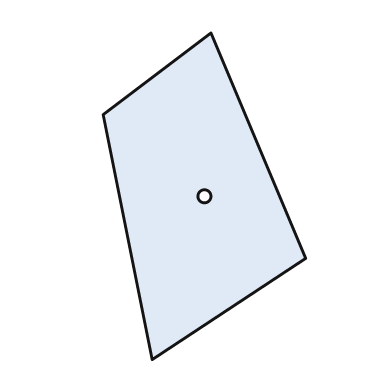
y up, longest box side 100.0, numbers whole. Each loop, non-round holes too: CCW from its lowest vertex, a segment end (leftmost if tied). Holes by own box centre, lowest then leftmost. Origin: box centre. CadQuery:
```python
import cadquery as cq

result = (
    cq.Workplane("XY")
    .moveTo(-16.0, -50.0)
    .lineTo(31.0, -19.0)
    .lineTo(2.0, 50.0)
    .lineTo(-31.0, 25.0)
    .close()
    .moveTo(0.0, 0.0)
    .circle(2.0)
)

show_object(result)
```